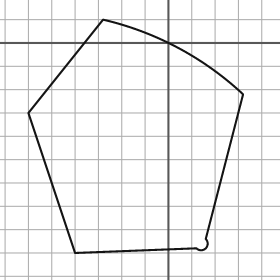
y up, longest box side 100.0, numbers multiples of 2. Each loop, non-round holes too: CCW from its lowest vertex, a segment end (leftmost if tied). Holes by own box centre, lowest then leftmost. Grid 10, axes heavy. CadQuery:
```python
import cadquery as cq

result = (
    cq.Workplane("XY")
    .moveTo(-40.0, -90.0)
    .lineTo(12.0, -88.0)
    .threePointArc((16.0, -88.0), (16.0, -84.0))
    .lineTo(32.0, -22.0)
    .threePointArc((4.0, -2.0), (-28.0, 10.0))
    .lineTo(-60.0, -30.0)
    .close()
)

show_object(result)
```